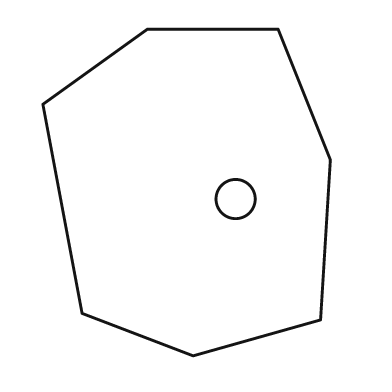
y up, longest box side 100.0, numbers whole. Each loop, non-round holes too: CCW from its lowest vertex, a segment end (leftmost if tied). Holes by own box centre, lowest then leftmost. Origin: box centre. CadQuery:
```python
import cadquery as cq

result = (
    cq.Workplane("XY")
    .moveTo(2.0, -50.0)
    .lineTo(41.0, -39.0)
    .lineTo(44.0, 10.0)
    .lineTo(28.0, 50.0)
    .lineTo(-12.0, 50.0)
    .lineTo(-44.0, 27.0)
    .lineTo(-32.0, -37.0)
    .close()
    .moveTo(15.0, -2.0)
    .circle(6.0)
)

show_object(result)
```